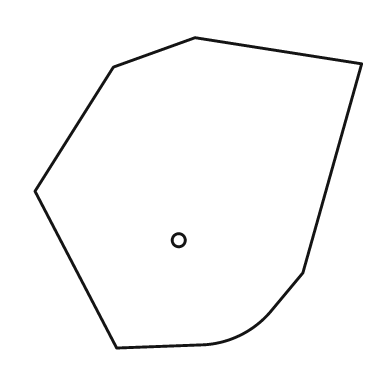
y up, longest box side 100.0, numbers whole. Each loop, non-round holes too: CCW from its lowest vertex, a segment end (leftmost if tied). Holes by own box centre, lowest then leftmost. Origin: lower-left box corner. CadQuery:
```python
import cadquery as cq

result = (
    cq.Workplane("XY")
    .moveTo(25.0, 0.0)
    .lineTo(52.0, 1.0)
    .threePointArc((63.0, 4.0), (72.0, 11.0))
    .lineTo(82.0, 23.0)
    .lineTo(100.0, 87.0)
    .lineTo(49.0, 95.0)
    .lineTo(24.0, 86.0)
    .lineTo(0.0, 48.0)
    .close()
    .moveTo(44.0, 33.0)
    .circle(2.0)
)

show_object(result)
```